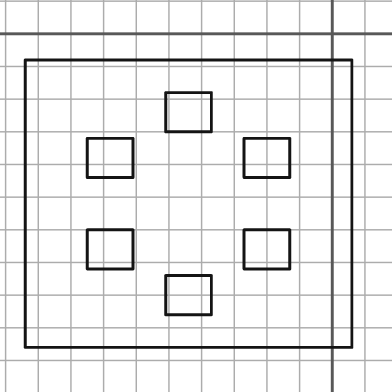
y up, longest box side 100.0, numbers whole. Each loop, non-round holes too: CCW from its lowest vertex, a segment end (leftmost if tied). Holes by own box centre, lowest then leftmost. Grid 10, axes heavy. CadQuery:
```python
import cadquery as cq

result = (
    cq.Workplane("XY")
    .moveTo(-94.0, -96.0)
    .lineTo(6.0, -96.0)
    .lineTo(6.0, -8.0)
    .lineTo(-94.0, -8.0)
    .close()
    .moveTo(-51.0, -86.0)
    .lineTo(-37.0, -86.0)
    .lineTo(-37.0, -74.0)
    .lineTo(-51.0, -74.0)
    .close()
    .moveTo(-75.0, -72.0)
    .lineTo(-61.0, -72.0)
    .lineTo(-61.0, -60.0)
    .lineTo(-75.0, -60.0)
    .close()
    .moveTo(-27.0, -72.0)
    .lineTo(-13.0, -72.0)
    .lineTo(-13.0, -60.0)
    .lineTo(-27.0, -60.0)
    .close()
    .moveTo(-75.0, -44.0)
    .lineTo(-61.0, -44.0)
    .lineTo(-61.0, -32.0)
    .lineTo(-75.0, -32.0)
    .close()
    .moveTo(-27.0, -44.0)
    .lineTo(-13.0, -44.0)
    .lineTo(-13.0, -32.0)
    .lineTo(-27.0, -32.0)
    .close()
    .moveTo(-51.0, -30.0)
    .lineTo(-37.0, -30.0)
    .lineTo(-37.0, -18.0)
    .lineTo(-51.0, -18.0)
    .close()
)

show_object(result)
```